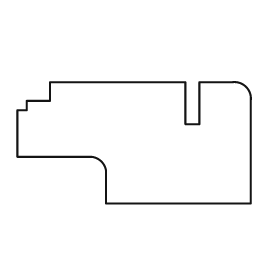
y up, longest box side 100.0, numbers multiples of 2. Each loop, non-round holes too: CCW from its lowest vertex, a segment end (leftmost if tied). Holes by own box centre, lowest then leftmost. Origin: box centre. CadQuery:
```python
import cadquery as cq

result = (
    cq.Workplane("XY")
    .moveTo(-12.0, -26.0)
    .lineTo(50.0, -26.0)
    .lineTo(50.0, 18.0)
    .threePointArc((48.0, 24.0), (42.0, 26.0))
    .lineTo(28.0, 26.0)
    .lineTo(28.0, 8.0)
    .lineTo(22.0, 8.0)
    .lineTo(22.0, 26.0)
    .lineTo(-36.0, 26.0)
    .lineTo(-36.0, 18.0)
    .lineTo(-46.0, 18.0)
    .lineTo(-46.0, 14.0)
    .lineTo(-50.0, 14.0)
    .lineTo(-50.0, -6.0)
    .lineTo(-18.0, -6.0)
    .threePointArc((-14.0, -8.0), (-12.0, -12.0))
    .close()
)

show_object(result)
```